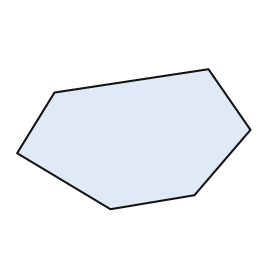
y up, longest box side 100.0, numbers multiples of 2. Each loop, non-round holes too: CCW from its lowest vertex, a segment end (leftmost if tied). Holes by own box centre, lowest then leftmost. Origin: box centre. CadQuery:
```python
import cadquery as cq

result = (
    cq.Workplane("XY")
    .moveTo(-10.0, -30.0)
    .lineTo(26.0, -24.0)
    .lineTo(50.0, 4.0)
    .lineTo(32.0, 30.0)
    .lineTo(-34.0, 20.0)
    .lineTo(-50.0, -6.0)
    .close()
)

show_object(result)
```